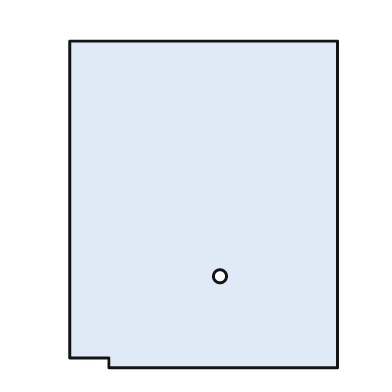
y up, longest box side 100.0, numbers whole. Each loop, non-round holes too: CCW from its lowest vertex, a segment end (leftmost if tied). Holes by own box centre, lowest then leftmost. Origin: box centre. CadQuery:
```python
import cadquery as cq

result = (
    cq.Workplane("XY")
    .moveTo(-29.0, -50.0)
    .lineTo(41.0, -50.0)
    .lineTo(41.0, 50.0)
    .lineTo(-41.0, 50.0)
    .lineTo(-41.0, -47.0)
    .lineTo(-29.0, -47.0)
    .close()
    .moveTo(5.0, -22.0)
    .circle(2.0)
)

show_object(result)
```